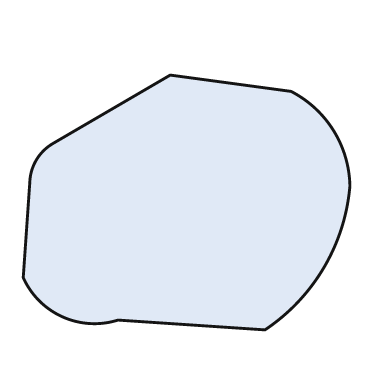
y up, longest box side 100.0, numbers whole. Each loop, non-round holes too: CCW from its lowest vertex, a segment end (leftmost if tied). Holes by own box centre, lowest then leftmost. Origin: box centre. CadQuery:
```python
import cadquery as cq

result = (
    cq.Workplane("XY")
    .moveTo(24.0, -39.0)
    .threePointArc((42.0, -20.0), (50.0, 5.0))
    .threePointArc((45.0, 22.0), (32.0, 34.0))
    .lineTo(-5.0, 39.0)
    .lineTo(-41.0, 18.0)
    .threePointArc((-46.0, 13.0), (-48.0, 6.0))
    .lineTo(-50.0, -23.0)
    .threePointArc((-38.0, -35.0), (-21.0, -36.0))
    .close()
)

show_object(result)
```